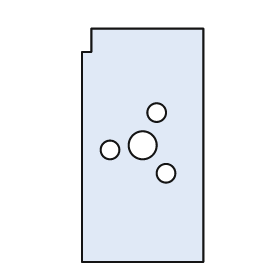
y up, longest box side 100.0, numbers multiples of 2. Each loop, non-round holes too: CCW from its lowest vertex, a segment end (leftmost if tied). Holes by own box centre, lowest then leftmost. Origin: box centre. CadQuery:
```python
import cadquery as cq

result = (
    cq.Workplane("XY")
    .moveTo(-26.0, -50.0)
    .lineTo(26.0, -50.0)
    .lineTo(26.0, 50.0)
    .lineTo(-22.0, 50.0)
    .lineTo(-22.0, 40.0)
    .lineTo(-26.0, 40.0)
    .close()
    .moveTo(10.0, -12.0)
    .circle(4.0)
    .moveTo(-14.0, -2.0)
    .circle(4.0)
    .moveTo(0.0, 0.0)
    .circle(6.0)
    .moveTo(6.0, 14.0)
    .circle(4.0)
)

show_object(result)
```